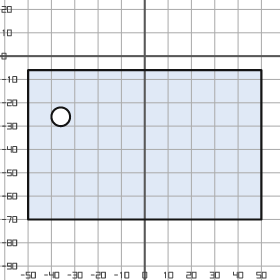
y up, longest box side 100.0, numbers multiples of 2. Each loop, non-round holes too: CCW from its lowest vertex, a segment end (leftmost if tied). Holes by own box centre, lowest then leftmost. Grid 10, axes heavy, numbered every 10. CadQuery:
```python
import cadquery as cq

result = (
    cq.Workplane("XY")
    .moveTo(-50.0, -70.0)
    .lineTo(50.0, -70.0)
    .lineTo(50.0, -6.0)
    .lineTo(-50.0, -6.0)
    .close()
    .moveTo(-36.0, -26.0)
    .circle(4.0)
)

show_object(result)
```